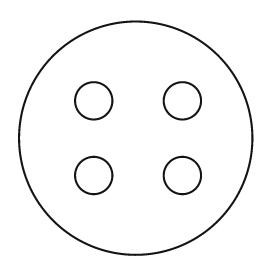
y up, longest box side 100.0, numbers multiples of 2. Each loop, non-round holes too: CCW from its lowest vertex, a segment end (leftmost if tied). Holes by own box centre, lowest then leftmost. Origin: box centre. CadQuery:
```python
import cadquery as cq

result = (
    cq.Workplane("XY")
    .moveTo(0.0, 0.0)
    .circle(50.0)
    .moveTo(-18.0, -16.0)
    .circle(8.0)
    .moveTo(20.0, -16.0)
    .circle(8.0)
    .moveTo(-18.0, 16.0)
    .circle(8.0)
    .moveTo(20.0, 16.0)
    .circle(8.0)
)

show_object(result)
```